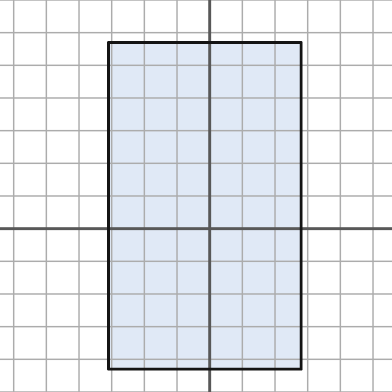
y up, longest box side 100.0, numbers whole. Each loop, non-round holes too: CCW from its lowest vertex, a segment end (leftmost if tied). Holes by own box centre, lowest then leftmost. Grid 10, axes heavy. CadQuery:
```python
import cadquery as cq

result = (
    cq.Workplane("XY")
    .moveTo(-31.0, -43.0)
    .lineTo(28.0, -43.0)
    .lineTo(28.0, 57.0)
    .lineTo(-31.0, 57.0)
    .close()
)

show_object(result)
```